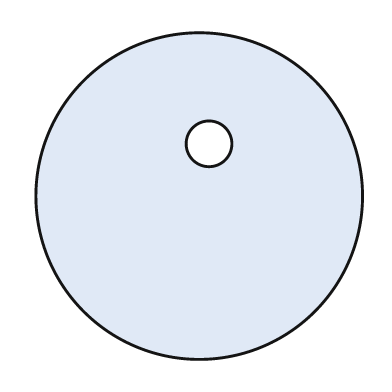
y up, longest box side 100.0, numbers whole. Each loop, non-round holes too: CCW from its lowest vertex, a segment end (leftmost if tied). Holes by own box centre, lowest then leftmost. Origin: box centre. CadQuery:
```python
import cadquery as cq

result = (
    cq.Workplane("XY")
    .moveTo(0.0, 0.0)
    .circle(50.0)
    .moveTo(3.0, 16.0)
    .circle(7.0)
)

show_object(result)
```